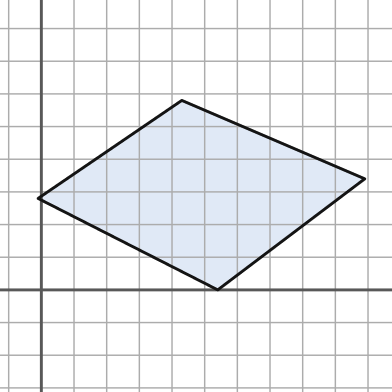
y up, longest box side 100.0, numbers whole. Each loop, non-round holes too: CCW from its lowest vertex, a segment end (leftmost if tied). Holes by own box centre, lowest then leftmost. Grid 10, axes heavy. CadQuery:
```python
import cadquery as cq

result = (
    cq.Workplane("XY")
    .moveTo(54.0, 0.0)
    .lineTo(99.0, 34.0)
    .lineTo(43.0, 58.0)
    .lineTo(-1.0, 28.0)
    .close()
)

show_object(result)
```